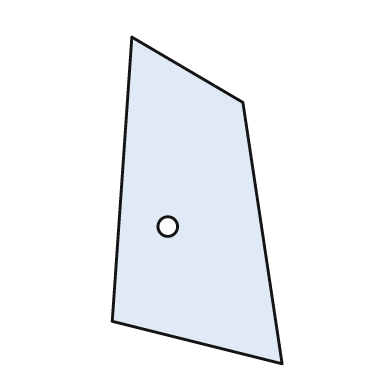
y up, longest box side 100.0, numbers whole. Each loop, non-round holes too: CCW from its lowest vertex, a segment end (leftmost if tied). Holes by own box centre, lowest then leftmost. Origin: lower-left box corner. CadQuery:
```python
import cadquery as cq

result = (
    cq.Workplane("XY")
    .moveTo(52.0, 0.0)
    .lineTo(40.0, 80.0)
    .lineTo(6.0, 100.0)
    .lineTo(0.0, 13.0)
    .close()
    .moveTo(17.0, 42.0)
    .circle(3.0)
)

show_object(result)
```